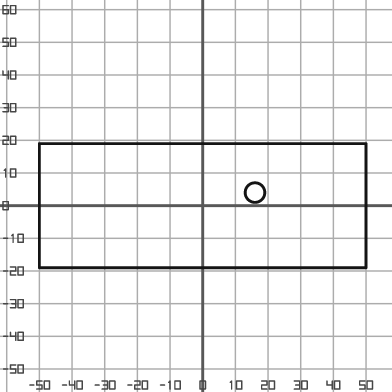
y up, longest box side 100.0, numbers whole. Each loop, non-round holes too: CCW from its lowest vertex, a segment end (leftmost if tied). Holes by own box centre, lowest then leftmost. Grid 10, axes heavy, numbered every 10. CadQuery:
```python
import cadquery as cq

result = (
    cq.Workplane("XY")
    .moveTo(-50.0, -19.0)
    .lineTo(50.0, -19.0)
    .lineTo(50.0, 19.0)
    .lineTo(-50.0, 19.0)
    .close()
    .moveTo(16.0, 4.0)
    .circle(3.0)
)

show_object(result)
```